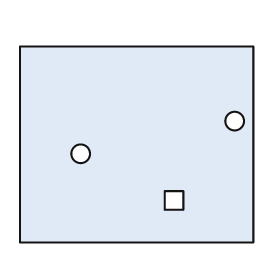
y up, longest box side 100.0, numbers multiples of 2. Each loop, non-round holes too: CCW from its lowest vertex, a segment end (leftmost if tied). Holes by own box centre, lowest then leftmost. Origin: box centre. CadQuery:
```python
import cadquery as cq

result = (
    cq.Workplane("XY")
    .moveTo(-50.0, -42.0)
    .lineTo(50.0, -42.0)
    .lineTo(50.0, 42.0)
    .lineTo(-50.0, 42.0)
    .close()
    .moveTo(12.0, -28.0)
    .lineTo(20.0, -28.0)
    .lineTo(20.0, -20.0)
    .lineTo(12.0, -20.0)
    .close()
    .moveTo(-24.0, -4.0)
    .circle(4.0)
    .moveTo(42.0, 10.0)
    .circle(4.0)
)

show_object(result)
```